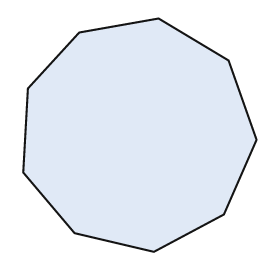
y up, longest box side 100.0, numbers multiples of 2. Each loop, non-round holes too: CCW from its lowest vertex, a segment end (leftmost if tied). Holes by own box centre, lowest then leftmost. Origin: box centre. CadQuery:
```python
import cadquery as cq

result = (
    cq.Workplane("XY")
    .moveTo(6.0, -50.0)
    .lineTo(36.0, -34.0)
    .lineTo(50.0, -2.0)
    .lineTo(38.0, 32.0)
    .lineTo(8.0, 50.0)
    .lineTo(-26.0, 44.0)
    .lineTo(-48.0, 20.0)
    .lineTo(-50.0, -16.0)
    .lineTo(-28.0, -42.0)
    .close()
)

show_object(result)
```